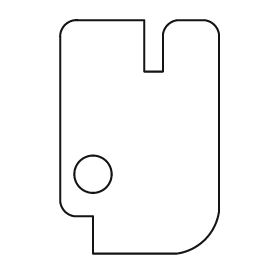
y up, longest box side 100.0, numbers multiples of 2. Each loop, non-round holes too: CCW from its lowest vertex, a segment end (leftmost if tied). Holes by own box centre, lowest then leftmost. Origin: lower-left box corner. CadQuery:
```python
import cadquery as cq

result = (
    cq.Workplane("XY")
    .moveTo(14.0, 0.0)
    .lineTo(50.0, 0.0)
    .threePointArc((62.0, 6.0), (68.0, 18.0))
    .lineTo(68.0, 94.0)
    .threePointArc((66.0, 98.0), (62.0, 100.0))
    .lineTo(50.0, 100.0)
    .threePointArc((46.0, 98.0), (44.0, 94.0))
    .lineTo(44.0, 78.0)
    .lineTo(36.0, 78.0)
    .lineTo(36.0, 100.0)
    .lineTo(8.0, 100.0)
    .threePointArc((2.0, 98.0), (0.0, 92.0))
    .lineTo(0.0, 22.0)
    .threePointArc((2.0, 18.0), (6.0, 16.0))
    .lineTo(14.0, 16.0)
    .close()
    .moveTo(14.0, 34.0)
    .circle(8.0)
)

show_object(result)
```